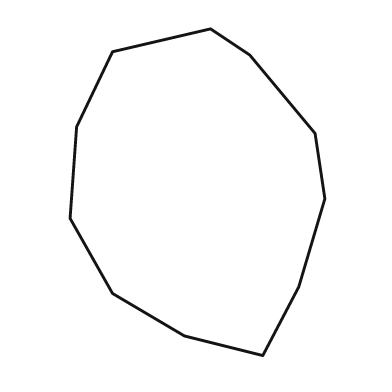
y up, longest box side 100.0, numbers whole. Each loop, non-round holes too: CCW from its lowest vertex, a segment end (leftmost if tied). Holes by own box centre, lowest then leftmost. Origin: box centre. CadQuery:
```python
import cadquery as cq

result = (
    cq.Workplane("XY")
    .moveTo(20.0, -50.0)
    .lineTo(31.0, -29.0)
    .lineTo(39.0, -2.0)
    .lineTo(36.0, 18.0)
    .lineTo(16.0, 42.0)
    .lineTo(4.0, 50.0)
    .lineTo(-26.0, 43.0)
    .lineTo(-37.0, 20.0)
    .lineTo(-39.0, -8.0)
    .lineTo(-26.0, -31.0)
    .lineTo(-4.0, -44.0)
    .close()
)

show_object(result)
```